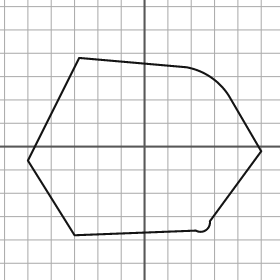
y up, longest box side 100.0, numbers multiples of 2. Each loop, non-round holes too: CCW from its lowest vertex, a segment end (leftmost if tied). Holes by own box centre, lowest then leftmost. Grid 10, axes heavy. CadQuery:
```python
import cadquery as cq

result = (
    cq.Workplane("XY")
    .moveTo(-30.0, -38.0)
    .lineTo(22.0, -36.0)
    .threePointArc((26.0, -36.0), (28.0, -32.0))
    .lineTo(50.0, -2.0)
    .lineTo(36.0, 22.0)
    .threePointArc((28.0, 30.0), (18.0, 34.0))
    .lineTo(-28.0, 38.0)
    .lineTo(-50.0, -6.0)
    .close()
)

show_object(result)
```